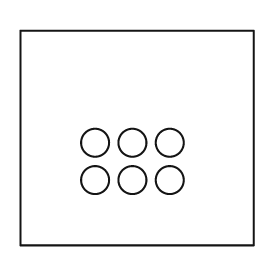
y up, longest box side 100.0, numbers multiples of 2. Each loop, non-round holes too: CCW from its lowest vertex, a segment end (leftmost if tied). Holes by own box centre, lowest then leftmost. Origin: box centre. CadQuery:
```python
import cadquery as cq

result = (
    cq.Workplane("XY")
    .moveTo(-50.0, -46.0)
    .lineTo(50.0, -46.0)
    .lineTo(50.0, 46.0)
    .lineTo(-50.0, 46.0)
    .close()
    .moveTo(-18.0, -18.0)
    .circle(6.0)
    .moveTo(-2.0, -18.0)
    .circle(6.0)
    .moveTo(14.0, -18.0)
    .circle(6.0)
    .moveTo(-18.0, -2.0)
    .circle(6.0)
    .moveTo(-2.0, -2.0)
    .circle(6.0)
    .moveTo(14.0, -2.0)
    .circle(6.0)
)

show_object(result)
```